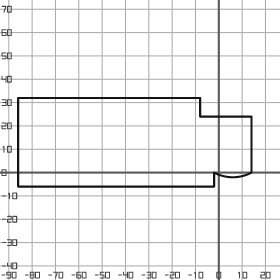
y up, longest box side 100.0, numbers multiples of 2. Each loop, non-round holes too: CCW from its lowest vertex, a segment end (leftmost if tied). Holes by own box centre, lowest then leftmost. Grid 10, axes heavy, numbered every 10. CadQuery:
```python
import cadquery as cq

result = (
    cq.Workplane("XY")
    .moveTo(-86.0, -6.0)
    .lineTo(-2.0, -6.0)
    .lineTo(-2.0, 0.0)
    .threePointArc((6.0, -2.0), (14.0, 0.0))
    .lineTo(14.0, 24.0)
    .lineTo(-8.0, 24.0)
    .lineTo(-8.0, 32.0)
    .lineTo(-86.0, 32.0)
    .close()
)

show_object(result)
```